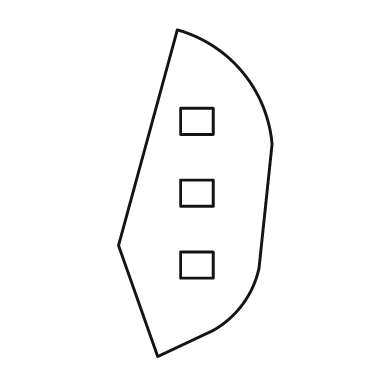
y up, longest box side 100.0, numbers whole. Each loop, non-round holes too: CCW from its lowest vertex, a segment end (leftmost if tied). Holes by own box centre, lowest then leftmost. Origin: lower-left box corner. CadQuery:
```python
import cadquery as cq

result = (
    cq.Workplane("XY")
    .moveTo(12.0, 0.0)
    .lineTo(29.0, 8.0)
    .threePointArc((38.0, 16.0), (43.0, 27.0))
    .lineTo(47.0, 65.0)
    .threePointArc((38.0, 87.0), (18.0, 100.0))
    .lineTo(0.0, 34.0)
    .close()
    .moveTo(19.0, 24.0)
    .lineTo(29.0, 24.0)
    .lineTo(29.0, 32.0)
    .lineTo(19.0, 32.0)
    .close()
    .moveTo(19.0, 46.0)
    .lineTo(29.0, 46.0)
    .lineTo(29.0, 54.0)
    .lineTo(19.0, 54.0)
    .close()
    .moveTo(19.0, 68.0)
    .lineTo(29.0, 68.0)
    .lineTo(29.0, 76.0)
    .lineTo(19.0, 76.0)
    .close()
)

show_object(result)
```